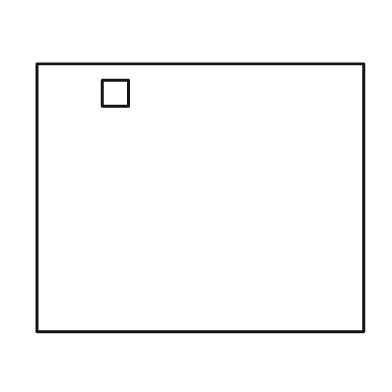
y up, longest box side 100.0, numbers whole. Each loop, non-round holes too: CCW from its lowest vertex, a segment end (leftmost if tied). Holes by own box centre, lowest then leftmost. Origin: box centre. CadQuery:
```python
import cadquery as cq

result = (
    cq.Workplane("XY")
    .moveTo(-50.0, -41.0)
    .lineTo(50.0, -41.0)
    .lineTo(50.0, 41.0)
    .lineTo(-50.0, 41.0)
    .close()
    .moveTo(-30.0, 28.0)
    .lineTo(-22.0, 28.0)
    .lineTo(-22.0, 36.0)
    .lineTo(-30.0, 36.0)
    .close()
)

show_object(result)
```